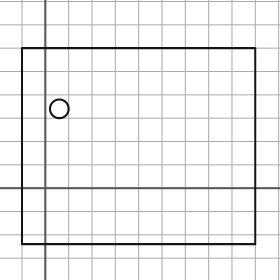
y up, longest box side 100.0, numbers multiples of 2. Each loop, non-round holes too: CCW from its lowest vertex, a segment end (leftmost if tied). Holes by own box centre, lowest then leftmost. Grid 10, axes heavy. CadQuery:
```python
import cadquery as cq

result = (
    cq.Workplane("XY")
    .moveTo(-10.0, -24.0)
    .lineTo(90.0, -24.0)
    .lineTo(90.0, 60.0)
    .lineTo(-10.0, 60.0)
    .close()
    .moveTo(6.0, 34.0)
    .circle(4.0)
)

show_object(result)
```